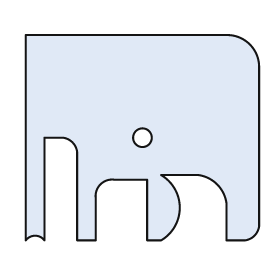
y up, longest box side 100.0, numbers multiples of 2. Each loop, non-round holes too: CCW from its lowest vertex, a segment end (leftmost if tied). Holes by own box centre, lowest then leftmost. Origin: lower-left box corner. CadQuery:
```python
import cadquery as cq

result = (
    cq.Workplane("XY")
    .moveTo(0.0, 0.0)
    .threePointArc((4.0, 2.0), (8.0, 0.0))
    .lineTo(8.0, 44.0)
    .lineTo(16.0, 44.0)
    .threePointArc((20.0, 42.0), (22.0, 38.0))
    .lineTo(22.0, 0.0)
    .lineTo(30.0, 0.0)
    .lineTo(30.0, 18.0)
    .threePointArc((32.0, 24.0), (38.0, 26.0))
    .lineTo(52.0, 26.0)
    .lineTo(52.0, 0.0)
    .lineTo(58.0, 0.0)
    .threePointArc((66.0, 14.0), (58.0, 28.0))
    .lineTo(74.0, 28.0)
    .threePointArc((82.0, 24.0), (86.0, 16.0))
    .lineTo(86.0, 0.0)
    .lineTo(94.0, 0.0)
    .threePointArc((98.0, 2.0), (100.0, 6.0))
    .lineTo(100.0, 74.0)
    .threePointArc((96.0, 84.0), (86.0, 88.0))
    .lineTo(0.0, 88.0)
    .close()
    .moveTo(50.0, 44.0)
    .circle(4.0)
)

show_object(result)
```